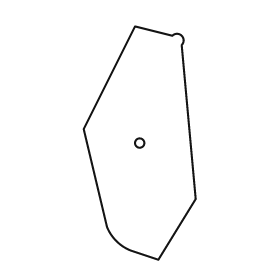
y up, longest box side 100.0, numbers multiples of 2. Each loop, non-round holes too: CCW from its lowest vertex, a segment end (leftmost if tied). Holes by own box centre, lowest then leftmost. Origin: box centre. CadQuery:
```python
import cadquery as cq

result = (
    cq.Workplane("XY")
    .moveTo(8.0, -50.0)
    .lineTo(24.0, -24.0)
    .lineTo(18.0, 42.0)
    .threePointArc((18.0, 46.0), (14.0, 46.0))
    .lineTo(-2.0, 50.0)
    .lineTo(-24.0, 6.0)
    .lineTo(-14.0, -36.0)
    .threePointArc((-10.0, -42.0), (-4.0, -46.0))
    .close()
    .moveTo(0.0, 0.0)
    .circle(2.0)
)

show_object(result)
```